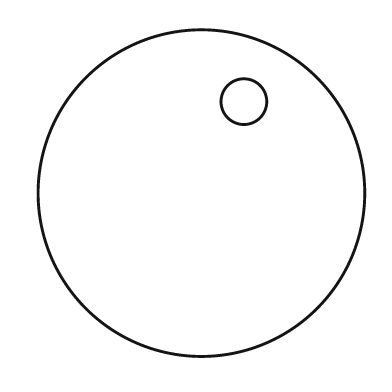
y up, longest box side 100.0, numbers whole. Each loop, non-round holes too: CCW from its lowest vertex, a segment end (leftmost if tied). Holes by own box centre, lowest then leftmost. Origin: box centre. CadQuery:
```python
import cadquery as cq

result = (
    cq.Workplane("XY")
    .moveTo(0.0, 0.0)
    .circle(50.0)
    .moveTo(13.0, 28.0)
    .circle(7.0)
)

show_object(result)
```